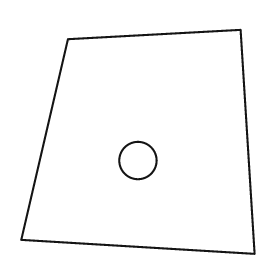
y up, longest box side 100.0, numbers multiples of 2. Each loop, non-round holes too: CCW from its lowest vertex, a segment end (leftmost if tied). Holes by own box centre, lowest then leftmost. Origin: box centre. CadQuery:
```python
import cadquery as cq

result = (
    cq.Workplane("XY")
    .moveTo(50.0, -48.0)
    .lineTo(44.0, 48.0)
    .lineTo(-30.0, 44.0)
    .lineTo(-50.0, -42.0)
    .close()
    .moveTo(0.0, -8.0)
    .circle(8.0)
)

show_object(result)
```